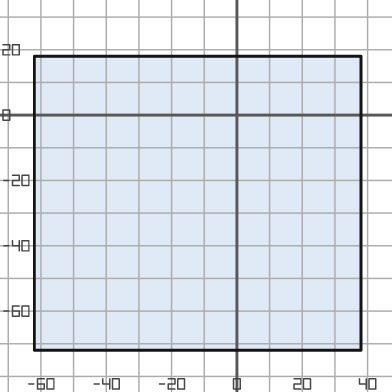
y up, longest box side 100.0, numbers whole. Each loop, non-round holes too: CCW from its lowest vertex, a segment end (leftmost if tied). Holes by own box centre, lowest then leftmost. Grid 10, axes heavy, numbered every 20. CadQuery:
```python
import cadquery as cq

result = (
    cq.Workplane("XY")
    .moveTo(-62.0, -72.0)
    .lineTo(38.0, -72.0)
    .lineTo(38.0, 18.0)
    .lineTo(-62.0, 18.0)
    .close()
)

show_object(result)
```